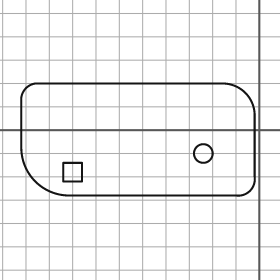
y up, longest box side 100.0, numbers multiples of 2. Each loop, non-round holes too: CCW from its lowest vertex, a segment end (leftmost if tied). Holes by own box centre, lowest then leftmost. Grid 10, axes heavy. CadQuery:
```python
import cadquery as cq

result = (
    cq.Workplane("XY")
    .moveTo(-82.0, -28.0)
    .lineTo(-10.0, -28.0)
    .threePointArc((-4.0, -26.0), (-2.0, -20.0))
    .lineTo(-2.0, 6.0)
    .threePointArc((-6.0, 16.0), (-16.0, 20.0))
    .lineTo(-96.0, 20.0)
    .threePointArc((-100.0, 18.0), (-102.0, 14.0))
    .lineTo(-102.0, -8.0)
    .threePointArc((-96.0, -22.0), (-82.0, -28.0))
    .close()
    .moveTo(-84.0, -22.0)
    .lineTo(-76.0, -22.0)
    .lineTo(-76.0, -14.0)
    .lineTo(-84.0, -14.0)
    .close()
    .moveTo(-24.0, -10.0)
    .circle(4.0)
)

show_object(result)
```